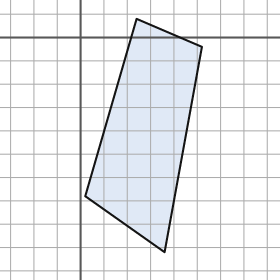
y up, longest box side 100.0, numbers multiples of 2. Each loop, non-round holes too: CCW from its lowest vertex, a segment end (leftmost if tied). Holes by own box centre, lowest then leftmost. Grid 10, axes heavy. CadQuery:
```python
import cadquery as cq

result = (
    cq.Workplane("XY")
    .moveTo(36.0, -92.0)
    .lineTo(52.0, -4.0)
    .lineTo(24.0, 8.0)
    .lineTo(2.0, -68.0)
    .close()
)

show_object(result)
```